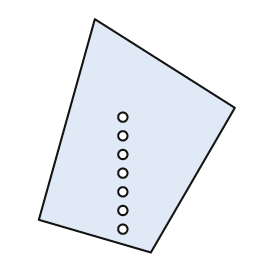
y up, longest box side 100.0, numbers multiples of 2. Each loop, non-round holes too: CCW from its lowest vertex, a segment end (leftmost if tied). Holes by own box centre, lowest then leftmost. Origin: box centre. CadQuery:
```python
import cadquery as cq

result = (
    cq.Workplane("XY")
    .moveTo(6.0, -50.0)
    .lineTo(42.0, 12.0)
    .lineTo(-18.0, 50.0)
    .lineTo(-42.0, -36.0)
    .close()
    .moveTo(-6.0, -40.0)
    .circle(2.0)
    .moveTo(-6.0, -32.0)
    .circle(2.0)
    .moveTo(-6.0, -24.0)
    .circle(2.0)
    .moveTo(-6.0, -16.0)
    .circle(2.0)
    .moveTo(-6.0, -8.0)
    .circle(2.0)
    .moveTo(-6.0, 0.0)
    .circle(2.0)
    .moveTo(-6.0, 8.0)
    .circle(2.0)
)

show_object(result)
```